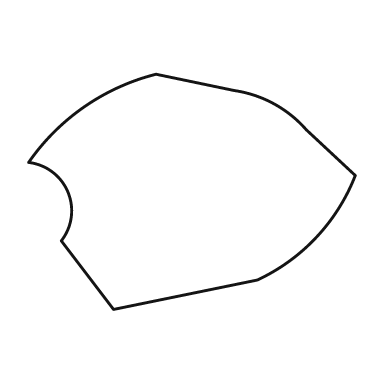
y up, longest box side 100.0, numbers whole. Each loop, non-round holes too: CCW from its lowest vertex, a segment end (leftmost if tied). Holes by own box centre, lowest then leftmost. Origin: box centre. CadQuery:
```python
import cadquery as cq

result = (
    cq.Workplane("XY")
    .moveTo(-24.0, -36.0)
    .lineTo(20.0, -27.0)
    .threePointArc((38.0, -14.0), (50.0, 5.0))
    .lineTo(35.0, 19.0)
    .threePointArc((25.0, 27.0), (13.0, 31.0))
    .lineTo(-11.0, 36.0)
    .threePointArc((-33.0, 26.0), (-50.0, 9.0))
    .threePointArc((-38.0, 0.0), (-40.0, -15.0))
    .close()
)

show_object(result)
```